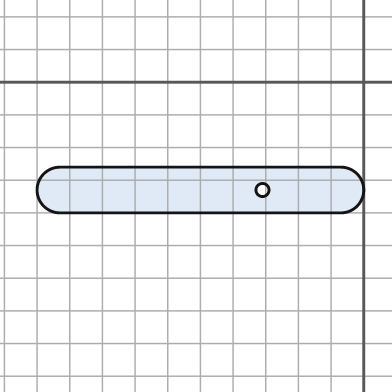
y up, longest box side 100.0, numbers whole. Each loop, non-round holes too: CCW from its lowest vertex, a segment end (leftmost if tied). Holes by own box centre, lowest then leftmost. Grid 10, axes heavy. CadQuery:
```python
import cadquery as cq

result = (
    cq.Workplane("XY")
    .moveTo(-93.0, -40.0)
    .lineTo(-7.0, -40.0)
    .threePointArc((0.0, -33.0), (-7.0, -26.0))
    .lineTo(-93.0, -26.0)
    .threePointArc((-100.0, -33.0), (-93.0, -40.0))
    .close()
    .moveTo(-31.0, -33.0)
    .circle(2.0)
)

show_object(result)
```